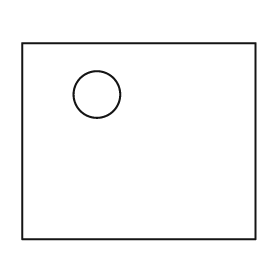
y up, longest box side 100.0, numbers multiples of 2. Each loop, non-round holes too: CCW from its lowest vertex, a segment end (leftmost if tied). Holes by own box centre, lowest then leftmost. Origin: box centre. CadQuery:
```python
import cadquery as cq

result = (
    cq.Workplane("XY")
    .moveTo(-50.0, -42.0)
    .lineTo(50.0, -42.0)
    .lineTo(50.0, 42.0)
    .lineTo(-50.0, 42.0)
    .close()
    .moveTo(-18.0, 20.0)
    .circle(10.0)
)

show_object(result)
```